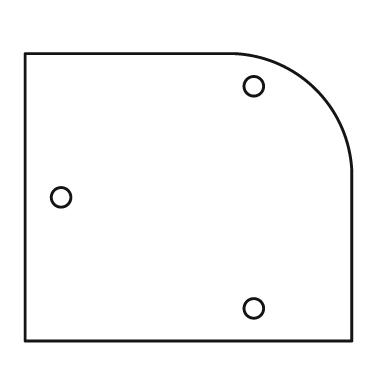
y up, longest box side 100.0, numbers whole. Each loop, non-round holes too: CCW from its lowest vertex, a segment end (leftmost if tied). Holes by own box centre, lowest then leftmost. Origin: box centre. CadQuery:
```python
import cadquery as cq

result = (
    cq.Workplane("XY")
    .moveTo(-50.0, -44.0)
    .lineTo(50.0, -44.0)
    .lineTo(50.0, 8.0)
    .threePointArc((39.0, 33.0), (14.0, 44.0))
    .lineTo(-50.0, 44.0)
    .close()
    .moveTo(20.0, -34.0)
    .circle(3.0)
    .moveTo(-39.0, 0.0)
    .circle(3.0)
    .moveTo(20.0, 34.0)
    .circle(3.0)
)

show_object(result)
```